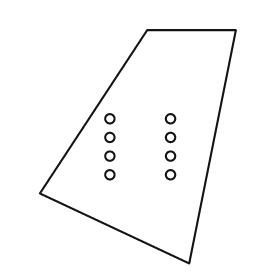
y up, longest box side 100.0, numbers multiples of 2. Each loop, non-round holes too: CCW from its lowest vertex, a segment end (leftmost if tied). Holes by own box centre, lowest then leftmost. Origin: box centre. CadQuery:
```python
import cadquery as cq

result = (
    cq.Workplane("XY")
    .moveTo(22.0, -50.0)
    .lineTo(42.0, 50.0)
    .lineTo(4.0, 50.0)
    .lineTo(-42.0, -20.0)
    .close()
    .moveTo(-12.0, -12.0)
    .circle(2.0)
    .moveTo(14.0, -12.0)
    .circle(2.0)
    .moveTo(-12.0, -4.0)
    .circle(2.0)
    .moveTo(14.0, -4.0)
    .circle(2.0)
    .moveTo(-12.0, 4.0)
    .circle(2.0)
    .moveTo(14.0, 4.0)
    .circle(2.0)
    .moveTo(-12.0, 12.0)
    .circle(2.0)
    .moveTo(14.0, 12.0)
    .circle(2.0)
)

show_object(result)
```